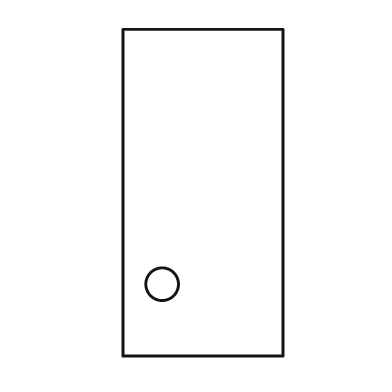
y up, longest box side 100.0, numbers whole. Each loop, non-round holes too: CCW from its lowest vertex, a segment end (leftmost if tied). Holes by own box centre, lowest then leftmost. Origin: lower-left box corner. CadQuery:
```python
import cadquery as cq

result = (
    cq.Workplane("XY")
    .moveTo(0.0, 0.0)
    .lineTo(49.0, 0.0)
    .lineTo(49.0, 100.0)
    .lineTo(0.0, 100.0)
    .close()
    .moveTo(12.0, 22.0)
    .circle(5.0)
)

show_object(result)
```